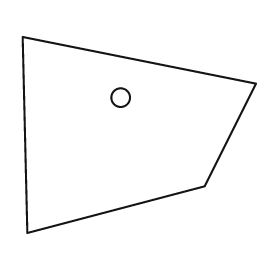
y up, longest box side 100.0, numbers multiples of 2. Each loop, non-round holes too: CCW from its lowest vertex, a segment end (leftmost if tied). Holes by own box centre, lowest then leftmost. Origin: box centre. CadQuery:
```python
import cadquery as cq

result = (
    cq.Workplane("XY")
    .moveTo(-48.0, -42.0)
    .lineTo(28.0, -22.0)
    .lineTo(50.0, 22.0)
    .lineTo(-50.0, 42.0)
    .close()
    .moveTo(-8.0, 16.0)
    .circle(4.0)
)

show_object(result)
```